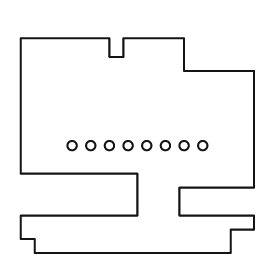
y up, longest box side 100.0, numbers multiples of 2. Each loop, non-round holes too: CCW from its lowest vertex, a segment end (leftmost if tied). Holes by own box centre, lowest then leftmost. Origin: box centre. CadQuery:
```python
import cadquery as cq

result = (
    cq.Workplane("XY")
    .moveTo(-44.0, -46.0)
    .lineTo(40.0, -46.0)
    .lineTo(40.0, -36.0)
    .lineTo(50.0, -36.0)
    .lineTo(50.0, -30.0)
    .lineTo(18.0, -30.0)
    .lineTo(18.0, -18.0)
    .lineTo(50.0, -18.0)
    .lineTo(50.0, 32.0)
    .lineTo(20.0, 32.0)
    .lineTo(20.0, 46.0)
    .lineTo(-6.0, 46.0)
    .lineTo(-6.0, 38.0)
    .lineTo(-12.0, 38.0)
    .lineTo(-12.0, 46.0)
    .lineTo(-50.0, 46.0)
    .lineTo(-50.0, -12.0)
    .lineTo(0.0, -12.0)
    .lineTo(0.0, -30.0)
    .lineTo(-50.0, -30.0)
    .lineTo(-50.0, -40.0)
    .lineTo(-44.0, -40.0)
    .close()
    .moveTo(-28.0, 0.0)
    .circle(2.0)
    .moveTo(-20.0, 0.0)
    .circle(2.0)
    .moveTo(-12.0, 0.0)
    .circle(2.0)
    .moveTo(-4.0, 0.0)
    .circle(2.0)
    .moveTo(4.0, 0.0)
    .circle(2.0)
    .moveTo(12.0, 0.0)
    .circle(2.0)
    .moveTo(20.0, 0.0)
    .circle(2.0)
    .moveTo(28.0, 0.0)
    .circle(2.0)
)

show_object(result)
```